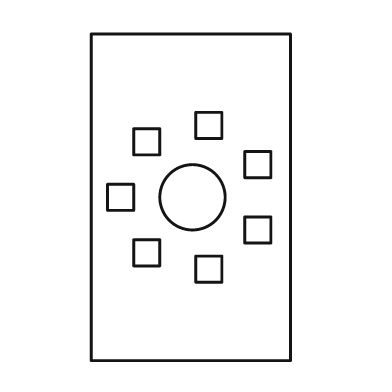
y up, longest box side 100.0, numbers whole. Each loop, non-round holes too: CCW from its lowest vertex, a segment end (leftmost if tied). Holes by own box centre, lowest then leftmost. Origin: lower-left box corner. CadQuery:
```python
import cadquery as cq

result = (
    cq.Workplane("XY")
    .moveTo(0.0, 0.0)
    .lineTo(61.0, 0.0)
    .lineTo(61.0, 100.0)
    .lineTo(0.0, 100.0)
    .close()
    .moveTo(32.0, 24.0)
    .lineTo(40.0, 24.0)
    .lineTo(40.0, 32.0)
    .lineTo(32.0, 32.0)
    .close()
    .moveTo(13.0, 29.0)
    .lineTo(21.0, 29.0)
    .lineTo(21.0, 37.0)
    .lineTo(13.0, 37.0)
    .close()
    .moveTo(47.0, 36.0)
    .lineTo(55.0, 36.0)
    .lineTo(55.0, 44.0)
    .lineTo(47.0, 44.0)
    .close()
    .moveTo(5.0, 46.0)
    .lineTo(13.0, 46.0)
    .lineTo(13.0, 54.0)
    .lineTo(5.0, 54.0)
    .close()
    .moveTo(31.0, 50.0)
    .circle(10.0)
    .moveTo(47.0, 56.0)
    .lineTo(55.0, 56.0)
    .lineTo(55.0, 64.0)
    .lineTo(47.0, 64.0)
    .close()
    .moveTo(13.0, 63.0)
    .lineTo(21.0, 63.0)
    .lineTo(21.0, 71.0)
    .lineTo(13.0, 71.0)
    .close()
    .moveTo(32.0, 68.0)
    .lineTo(40.0, 68.0)
    .lineTo(40.0, 76.0)
    .lineTo(32.0, 76.0)
    .close()
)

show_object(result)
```